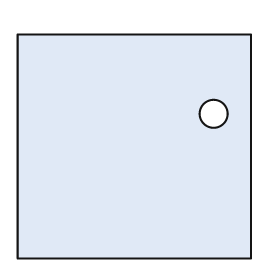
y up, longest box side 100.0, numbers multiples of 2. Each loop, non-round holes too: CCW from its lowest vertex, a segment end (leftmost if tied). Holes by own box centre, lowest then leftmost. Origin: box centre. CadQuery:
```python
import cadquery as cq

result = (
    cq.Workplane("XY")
    .moveTo(-50.0, -48.0)
    .lineTo(50.0, -48.0)
    .lineTo(50.0, 48.0)
    .lineTo(-50.0, 48.0)
    .close()
    .moveTo(34.0, 14.0)
    .circle(6.0)
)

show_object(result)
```